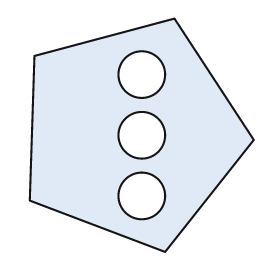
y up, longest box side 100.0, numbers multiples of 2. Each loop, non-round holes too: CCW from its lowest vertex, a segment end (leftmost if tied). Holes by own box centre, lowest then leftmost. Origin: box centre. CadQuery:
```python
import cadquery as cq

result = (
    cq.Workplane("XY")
    .moveTo(10.0, -50.0)
    .lineTo(48.0, -2.0)
    .lineTo(14.0, 50.0)
    .lineTo(-46.0, 34.0)
    .lineTo(-48.0, -28.0)
    .close()
    .moveTo(0.0, -26.0)
    .circle(10.0)
    .moveTo(0.0, 0.0)
    .circle(10.0)
    .moveTo(0.0, 26.0)
    .circle(10.0)
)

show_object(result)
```